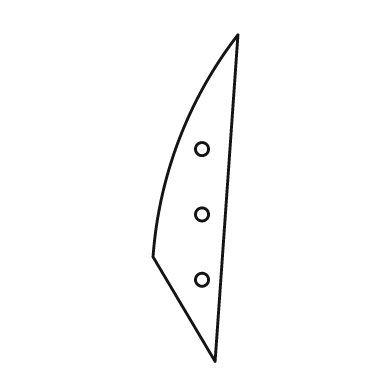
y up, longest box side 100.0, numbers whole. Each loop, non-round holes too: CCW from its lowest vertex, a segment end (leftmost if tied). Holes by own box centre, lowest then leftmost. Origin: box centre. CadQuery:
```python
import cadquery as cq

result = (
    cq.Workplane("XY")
    .moveTo(6.0, -50.0)
    .lineTo(13.0, 50.0)
    .threePointArc((-5.0, 18.0), (-13.0, -18.0))
    .close()
    .moveTo(2.0, -25.0)
    .circle(2.0)
    .moveTo(2.0, -5.0)
    .circle(2.0)
    .moveTo(2.0, 15.0)
    .circle(2.0)
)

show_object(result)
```